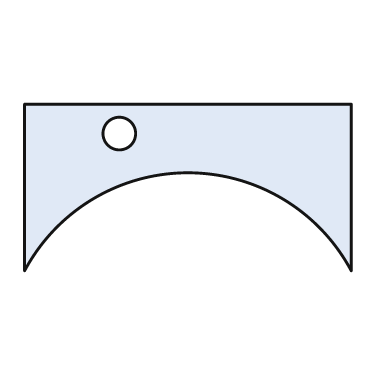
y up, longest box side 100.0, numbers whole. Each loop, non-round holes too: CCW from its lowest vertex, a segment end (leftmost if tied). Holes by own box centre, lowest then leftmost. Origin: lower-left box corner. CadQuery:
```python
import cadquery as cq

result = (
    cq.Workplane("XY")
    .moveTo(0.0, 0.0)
    .threePointArc((50.0, 30.0), (100.0, 0.0))
    .lineTo(100.0, 51.0)
    .lineTo(0.0, 51.0)
    .close()
    .moveTo(29.0, 42.0)
    .circle(5.0)
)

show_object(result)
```